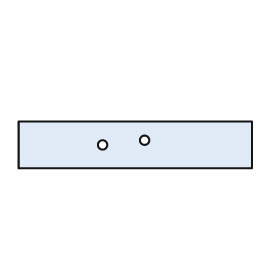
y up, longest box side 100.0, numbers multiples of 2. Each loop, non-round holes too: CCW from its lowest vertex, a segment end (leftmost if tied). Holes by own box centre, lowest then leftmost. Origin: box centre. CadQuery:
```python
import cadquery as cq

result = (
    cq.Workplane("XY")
    .moveTo(-50.0, -10.0)
    .lineTo(50.0, -10.0)
    .lineTo(50.0, 10.0)
    .lineTo(-50.0, 10.0)
    .close()
    .moveTo(-14.0, 0.0)
    .circle(2.0)
    .moveTo(4.0, 2.0)
    .circle(2.0)
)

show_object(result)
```